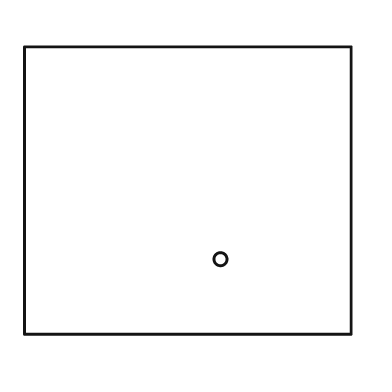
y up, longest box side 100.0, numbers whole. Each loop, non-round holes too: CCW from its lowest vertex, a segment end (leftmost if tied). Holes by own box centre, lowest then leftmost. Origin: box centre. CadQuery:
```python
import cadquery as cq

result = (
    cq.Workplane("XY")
    .moveTo(-50.0, -44.0)
    .lineTo(50.0, -44.0)
    .lineTo(50.0, 44.0)
    .lineTo(-50.0, 44.0)
    .close()
    .moveTo(10.0, -21.0)
    .circle(2.0)
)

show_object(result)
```